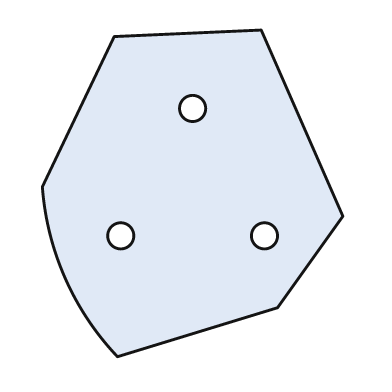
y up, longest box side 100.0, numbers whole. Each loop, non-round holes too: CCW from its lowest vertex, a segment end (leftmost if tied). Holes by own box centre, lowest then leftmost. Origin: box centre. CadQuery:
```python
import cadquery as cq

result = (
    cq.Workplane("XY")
    .moveTo(-23.0, -50.0)
    .lineTo(26.0, -35.0)
    .lineTo(46.0, -7.0)
    .lineTo(21.0, 50.0)
    .lineTo(-24.0, 48.0)
    .lineTo(-46.0, 2.0)
    .threePointArc((-39.0, -26.0), (-23.0, -50.0))
    .close()
    .moveTo(-22.0, -13.0)
    .circle(4.0)
    .moveTo(22.0, -13.0)
    .circle(4.0)
    .moveTo(0.0, 26.0)
    .circle(4.0)
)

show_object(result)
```